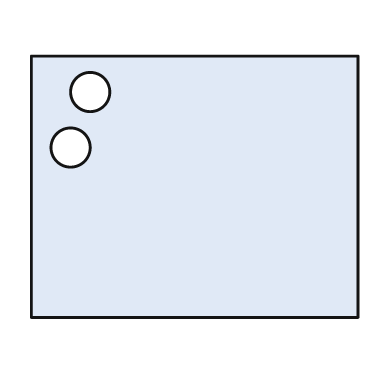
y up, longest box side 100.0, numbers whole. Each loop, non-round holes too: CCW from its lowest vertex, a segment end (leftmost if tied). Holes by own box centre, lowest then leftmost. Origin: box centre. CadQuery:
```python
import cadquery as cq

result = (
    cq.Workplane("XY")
    .moveTo(-50.0, -40.0)
    .lineTo(50.0, -40.0)
    .lineTo(50.0, 40.0)
    .lineTo(-50.0, 40.0)
    .close()
    .moveTo(-38.0, 12.0)
    .circle(6.0)
    .moveTo(-32.0, 29.0)
    .circle(6.0)
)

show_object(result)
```